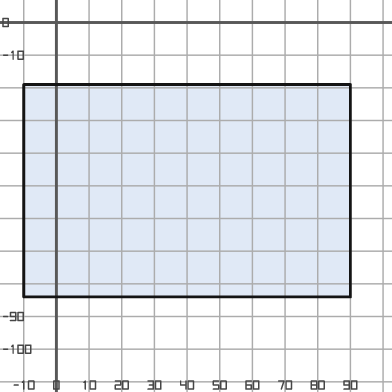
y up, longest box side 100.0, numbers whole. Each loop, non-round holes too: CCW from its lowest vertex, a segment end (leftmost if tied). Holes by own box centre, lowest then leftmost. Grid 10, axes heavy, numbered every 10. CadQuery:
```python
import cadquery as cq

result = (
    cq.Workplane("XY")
    .moveTo(-10.0, -84.0)
    .lineTo(90.0, -84.0)
    .lineTo(90.0, -19.0)
    .lineTo(-10.0, -19.0)
    .close()
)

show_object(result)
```